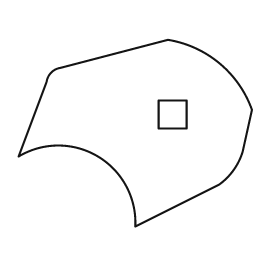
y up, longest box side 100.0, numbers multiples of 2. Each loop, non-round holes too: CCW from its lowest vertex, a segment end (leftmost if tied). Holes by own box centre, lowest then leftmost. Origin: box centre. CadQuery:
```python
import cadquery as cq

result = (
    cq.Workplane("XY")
    .moveTo(0.0, -40.0)
    .lineTo(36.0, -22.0)
    .threePointArc((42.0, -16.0), (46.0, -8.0))
    .lineTo(50.0, 10.0)
    .threePointArc((36.0, 30.0), (14.0, 40.0))
    .lineTo(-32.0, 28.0)
    .threePointArc((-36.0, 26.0), (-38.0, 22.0))
    .lineTo(-50.0, -10.0)
    .threePointArc((-16.0, -10.0), (0.0, -40.0))
    .close()
    .moveTo(10.0, 2.0)
    .lineTo(22.0, 2.0)
    .lineTo(22.0, 14.0)
    .lineTo(10.0, 14.0)
    .close()
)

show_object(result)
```